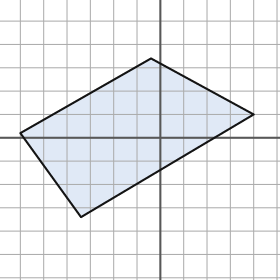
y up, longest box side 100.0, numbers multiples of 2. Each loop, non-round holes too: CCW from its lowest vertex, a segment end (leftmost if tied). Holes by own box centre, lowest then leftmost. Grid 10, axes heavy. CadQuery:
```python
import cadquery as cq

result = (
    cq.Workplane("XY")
    .moveTo(-34.0, -34.0)
    .lineTo(40.0, 10.0)
    .lineTo(-4.0, 34.0)
    .lineTo(-60.0, 2.0)
    .close()
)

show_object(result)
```